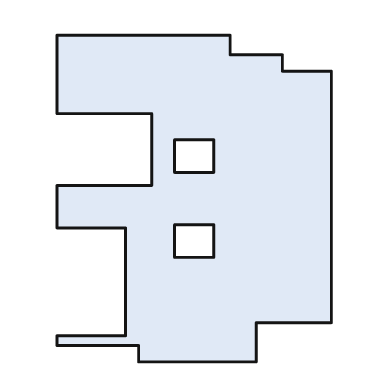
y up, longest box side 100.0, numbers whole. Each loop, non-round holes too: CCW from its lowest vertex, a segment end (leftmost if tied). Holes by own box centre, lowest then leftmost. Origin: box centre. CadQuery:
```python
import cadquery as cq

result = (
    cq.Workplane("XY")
    .moveTo(-17.0, -50.0)
    .lineTo(19.0, -50.0)
    .lineTo(19.0, -38.0)
    .lineTo(42.0, -38.0)
    .lineTo(42.0, 39.0)
    .lineTo(27.0, 39.0)
    .lineTo(27.0, 44.0)
    .lineTo(11.0, 44.0)
    .lineTo(11.0, 50.0)
    .lineTo(-42.0, 50.0)
    .lineTo(-42.0, 26.0)
    .lineTo(-13.0, 26.0)
    .lineTo(-13.0, 4.0)
    .lineTo(-42.0, 4.0)
    .lineTo(-42.0, -9.0)
    .lineTo(-21.0, -9.0)
    .lineTo(-21.0, -42.0)
    .lineTo(-42.0, -42.0)
    .lineTo(-42.0, -45.0)
    .lineTo(-17.0, -45.0)
    .close()
    .moveTo(-6.0, -18.0)
    .lineTo(6.0, -18.0)
    .lineTo(6.0, -8.0)
    .lineTo(-6.0, -8.0)
    .close()
    .moveTo(-6.0, 8.0)
    .lineTo(6.0, 8.0)
    .lineTo(6.0, 18.0)
    .lineTo(-6.0, 18.0)
    .close()
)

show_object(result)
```